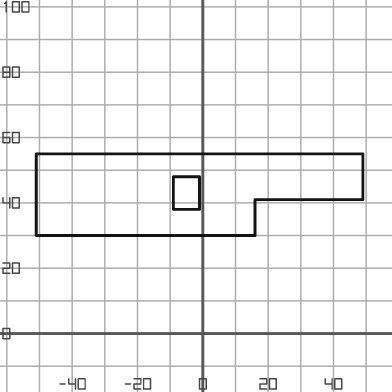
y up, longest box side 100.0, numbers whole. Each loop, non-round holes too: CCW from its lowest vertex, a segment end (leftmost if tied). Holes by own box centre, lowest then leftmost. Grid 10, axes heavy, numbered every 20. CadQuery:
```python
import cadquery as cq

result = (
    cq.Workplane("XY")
    .moveTo(-51.0, 30.0)
    .lineTo(16.0, 30.0)
    .lineTo(16.0, 41.0)
    .lineTo(49.0, 41.0)
    .lineTo(49.0, 55.0)
    .lineTo(-51.0, 55.0)
    .close()
    .moveTo(-9.0, 38.0)
    .lineTo(-1.0, 38.0)
    .lineTo(-1.0, 48.0)
    .lineTo(-9.0, 48.0)
    .close()
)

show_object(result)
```